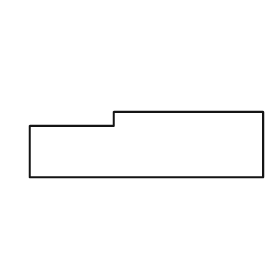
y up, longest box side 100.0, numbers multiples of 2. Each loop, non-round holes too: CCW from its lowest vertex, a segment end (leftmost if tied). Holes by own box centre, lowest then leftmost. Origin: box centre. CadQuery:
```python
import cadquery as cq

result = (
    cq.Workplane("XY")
    .moveTo(-50.0, -14.0)
    .lineTo(50.0, -14.0)
    .lineTo(50.0, 14.0)
    .lineTo(-14.0, 14.0)
    .lineTo(-14.0, 8.0)
    .lineTo(-50.0, 8.0)
    .close()
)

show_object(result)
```